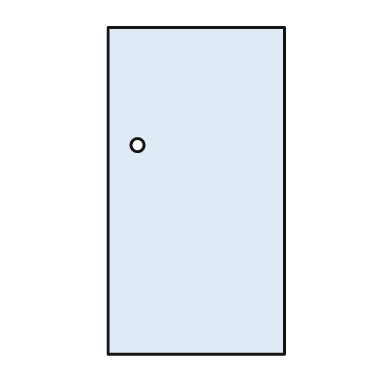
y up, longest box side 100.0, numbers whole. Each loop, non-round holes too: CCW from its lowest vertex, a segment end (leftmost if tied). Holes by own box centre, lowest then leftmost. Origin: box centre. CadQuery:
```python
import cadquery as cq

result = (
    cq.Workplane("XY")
    .moveTo(-27.0, -50.0)
    .lineTo(27.0, -50.0)
    .lineTo(27.0, 50.0)
    .lineTo(-27.0, 50.0)
    .close()
    .moveTo(-18.0, 14.0)
    .circle(2.0)
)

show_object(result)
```